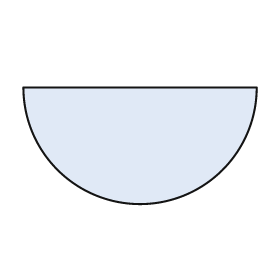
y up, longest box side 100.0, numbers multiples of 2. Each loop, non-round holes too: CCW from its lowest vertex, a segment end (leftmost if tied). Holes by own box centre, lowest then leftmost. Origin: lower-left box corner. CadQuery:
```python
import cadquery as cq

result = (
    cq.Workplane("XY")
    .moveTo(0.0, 50.0)
    .threePointArc((50.0, 0.0), (100.0, 50.0))
    .close()
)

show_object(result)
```